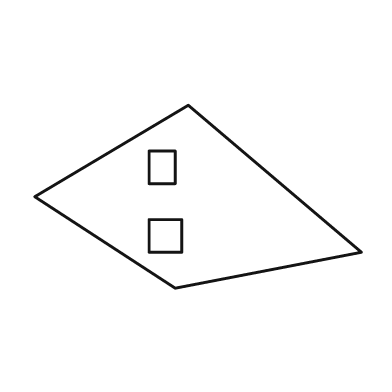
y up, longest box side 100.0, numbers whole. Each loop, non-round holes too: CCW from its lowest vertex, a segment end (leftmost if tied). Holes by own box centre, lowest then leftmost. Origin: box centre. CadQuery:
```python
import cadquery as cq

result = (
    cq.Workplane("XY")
    .moveTo(-7.0, -28.0)
    .lineTo(50.0, -17.0)
    .lineTo(-3.0, 28.0)
    .lineTo(-50.0, 0.0)
    .close()
    .moveTo(-15.0, -17.0)
    .lineTo(-5.0, -17.0)
    .lineTo(-5.0, -7.0)
    .lineTo(-15.0, -7.0)
    .close()
    .moveTo(-15.0, 4.0)
    .lineTo(-7.0, 4.0)
    .lineTo(-7.0, 14.0)
    .lineTo(-15.0, 14.0)
    .close()
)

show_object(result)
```